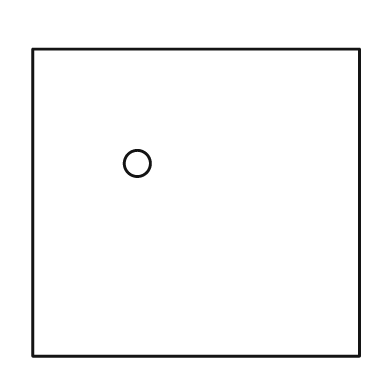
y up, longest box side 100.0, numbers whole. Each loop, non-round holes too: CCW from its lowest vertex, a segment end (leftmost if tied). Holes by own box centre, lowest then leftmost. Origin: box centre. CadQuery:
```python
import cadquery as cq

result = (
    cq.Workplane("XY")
    .moveTo(-50.0, -47.0)
    .lineTo(50.0, -47.0)
    .lineTo(50.0, 47.0)
    .lineTo(-50.0, 47.0)
    .close()
    .moveTo(-18.0, 12.0)
    .circle(4.0)
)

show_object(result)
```